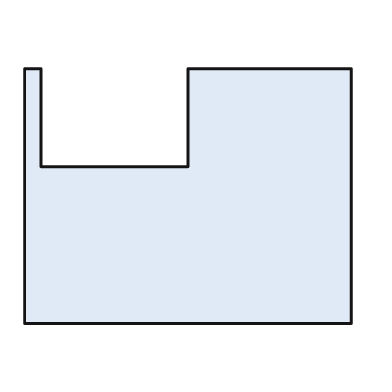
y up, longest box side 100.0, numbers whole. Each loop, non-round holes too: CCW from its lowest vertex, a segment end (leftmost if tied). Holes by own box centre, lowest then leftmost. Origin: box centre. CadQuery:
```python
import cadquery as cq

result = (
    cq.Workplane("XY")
    .moveTo(-50.0, -39.0)
    .lineTo(50.0, -39.0)
    .lineTo(50.0, 39.0)
    .lineTo(0.0, 39.0)
    .lineTo(0.0, 9.0)
    .lineTo(-45.0, 9.0)
    .lineTo(-45.0, 39.0)
    .lineTo(-50.0, 39.0)
    .close()
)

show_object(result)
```